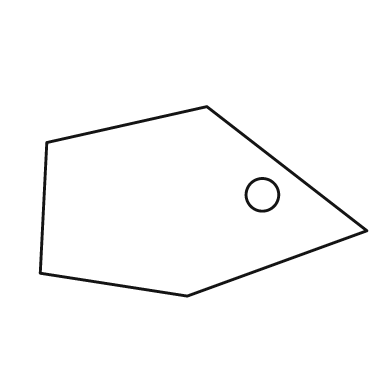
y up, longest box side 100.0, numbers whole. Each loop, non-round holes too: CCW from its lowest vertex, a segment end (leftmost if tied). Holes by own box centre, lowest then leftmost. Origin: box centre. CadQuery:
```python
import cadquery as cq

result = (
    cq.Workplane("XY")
    .moveTo(-5.0, -29.0)
    .lineTo(50.0, -9.0)
    .lineTo(1.0, 29.0)
    .lineTo(-48.0, 18.0)
    .lineTo(-50.0, -22.0)
    .close()
    .moveTo(18.0, 2.0)
    .circle(5.0)
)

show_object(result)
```